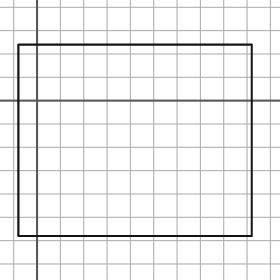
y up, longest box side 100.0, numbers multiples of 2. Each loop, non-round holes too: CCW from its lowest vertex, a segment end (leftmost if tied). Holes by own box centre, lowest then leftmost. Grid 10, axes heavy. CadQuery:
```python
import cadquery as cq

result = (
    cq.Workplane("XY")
    .moveTo(-8.0, -58.0)
    .lineTo(92.0, -58.0)
    .lineTo(92.0, 24.0)
    .lineTo(-8.0, 24.0)
    .close()
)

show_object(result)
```